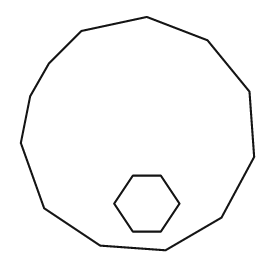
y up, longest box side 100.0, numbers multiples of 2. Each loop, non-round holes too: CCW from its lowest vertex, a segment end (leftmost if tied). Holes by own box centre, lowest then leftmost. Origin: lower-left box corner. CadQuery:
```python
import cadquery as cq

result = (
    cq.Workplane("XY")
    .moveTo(62.0, 0.0)
    .lineTo(86.0, 14.0)
    .lineTo(100.0, 40.0)
    .lineTo(98.0, 68.0)
    .lineTo(80.0, 90.0)
    .lineTo(54.0, 100.0)
    .lineTo(26.0, 94.0)
    .lineTo(12.0, 80.0)
    .lineTo(4.0, 66.0)
    .lineTo(0.0, 46.0)
    .lineTo(10.0, 18.0)
    .lineTo(34.0, 2.0)
    .close()
    .moveTo(48.0, 8.0)
    .lineTo(60.0, 8.0)
    .lineTo(68.0, 20.0)
    .lineTo(60.0, 32.0)
    .lineTo(48.0, 32.0)
    .lineTo(40.0, 20.0)
    .close()
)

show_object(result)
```